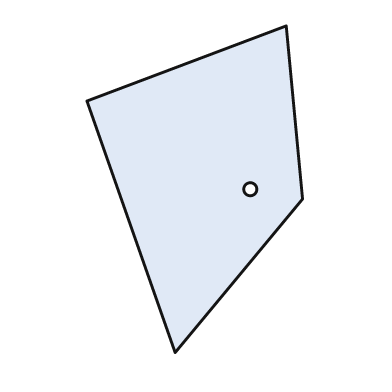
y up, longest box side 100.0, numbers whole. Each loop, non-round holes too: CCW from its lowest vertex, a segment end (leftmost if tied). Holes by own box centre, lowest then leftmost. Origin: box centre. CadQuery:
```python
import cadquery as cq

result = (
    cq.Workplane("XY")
    .moveTo(-6.0, -50.0)
    .lineTo(33.0, -3.0)
    .lineTo(28.0, 50.0)
    .lineTo(-33.0, 27.0)
    .close()
    .moveTo(17.0, 0.0)
    .circle(2.0)
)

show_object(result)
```